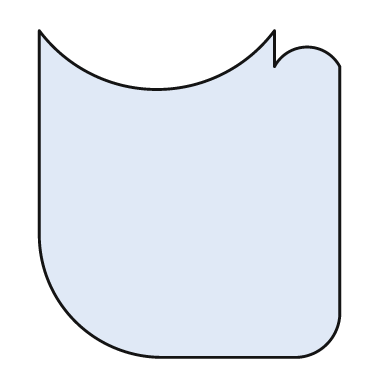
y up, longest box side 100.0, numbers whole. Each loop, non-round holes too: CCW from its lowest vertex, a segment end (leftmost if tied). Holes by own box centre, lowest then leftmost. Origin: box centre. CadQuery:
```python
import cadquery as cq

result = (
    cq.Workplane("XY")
    .moveTo(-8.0, -50.0)
    .lineTo(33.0, -50.0)
    .threePointArc((42.0, -46.0), (46.0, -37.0))
    .lineTo(46.0, 39.0)
    .threePointArc((36.0, 45.0), (26.0, 39.0))
    .lineTo(26.0, 50.0)
    .threePointArc((-10.0, 32.0), (-46.0, 50.0))
    .lineTo(-46.0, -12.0)
    .threePointArc((-35.0, -39.0), (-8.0, -50.0))
    .close()
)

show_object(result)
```